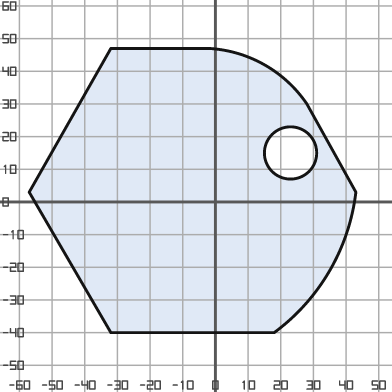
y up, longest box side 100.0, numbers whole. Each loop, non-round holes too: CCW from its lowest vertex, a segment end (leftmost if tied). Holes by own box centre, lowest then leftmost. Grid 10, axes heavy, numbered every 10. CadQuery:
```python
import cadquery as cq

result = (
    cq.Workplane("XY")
    .moveTo(-32.0, -40.0)
    .lineTo(18.0, -40.0)
    .threePointArc((35.0, -21.0), (43.0, 3.0))
    .lineTo(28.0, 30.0)
    .threePointArc((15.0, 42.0), (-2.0, 47.0))
    .lineTo(-32.0, 47.0)
    .lineTo(-57.0, 3.0)
    .close()
    .moveTo(23.0, 15.0)
    .circle(8.0)
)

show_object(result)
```